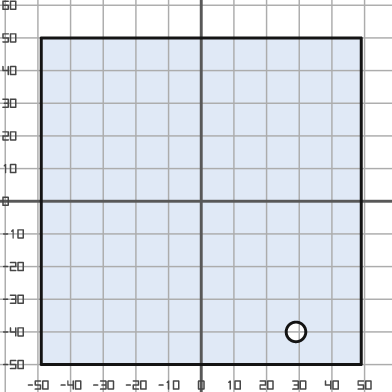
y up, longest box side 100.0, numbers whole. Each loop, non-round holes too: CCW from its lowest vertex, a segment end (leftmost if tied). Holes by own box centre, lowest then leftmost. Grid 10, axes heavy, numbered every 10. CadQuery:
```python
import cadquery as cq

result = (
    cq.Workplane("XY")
    .moveTo(-49.0, -50.0)
    .lineTo(49.0, -50.0)
    .lineTo(49.0, 50.0)
    .lineTo(-49.0, 50.0)
    .close()
    .moveTo(29.0, -40.0)
    .circle(3.0)
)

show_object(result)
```